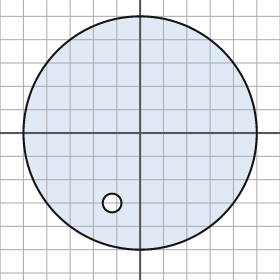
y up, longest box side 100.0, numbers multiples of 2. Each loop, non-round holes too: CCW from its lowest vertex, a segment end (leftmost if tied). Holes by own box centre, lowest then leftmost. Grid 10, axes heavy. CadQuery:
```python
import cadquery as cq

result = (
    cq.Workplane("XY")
    .moveTo(0.0, 0.0)
    .circle(50.0)
    .moveTo(-12.0, -30.0)
    .circle(4.0)
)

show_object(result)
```